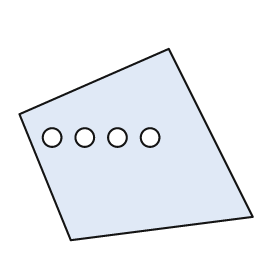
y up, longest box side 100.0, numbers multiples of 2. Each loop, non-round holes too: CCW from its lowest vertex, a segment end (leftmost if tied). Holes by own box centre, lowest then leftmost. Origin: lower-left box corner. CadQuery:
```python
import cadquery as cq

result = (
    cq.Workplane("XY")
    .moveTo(22.0, 0.0)
    .lineTo(100.0, 10.0)
    .lineTo(64.0, 82.0)
    .lineTo(0.0, 54.0)
    .close()
    .moveTo(14.0, 44.0)
    .circle(4.0)
    .moveTo(28.0, 44.0)
    .circle(4.0)
    .moveTo(42.0, 44.0)
    .circle(4.0)
    .moveTo(56.0, 44.0)
    .circle(4.0)
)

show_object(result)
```